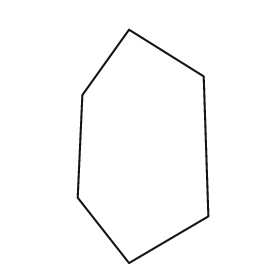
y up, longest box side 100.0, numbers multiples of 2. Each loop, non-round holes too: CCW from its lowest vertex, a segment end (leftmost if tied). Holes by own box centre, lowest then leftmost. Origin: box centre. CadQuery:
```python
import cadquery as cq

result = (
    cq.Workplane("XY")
    .moveTo(-6.0, -50.0)
    .lineTo(28.0, -30.0)
    .lineTo(26.0, 30.0)
    .lineTo(-6.0, 50.0)
    .lineTo(-26.0, 22.0)
    .lineTo(-28.0, -22.0)
    .close()
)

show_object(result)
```